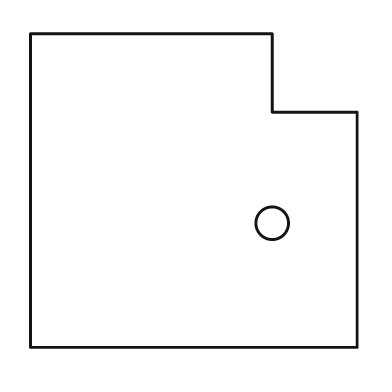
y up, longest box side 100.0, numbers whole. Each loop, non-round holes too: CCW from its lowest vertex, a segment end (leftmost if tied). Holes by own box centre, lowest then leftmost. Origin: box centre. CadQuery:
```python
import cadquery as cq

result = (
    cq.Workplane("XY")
    .moveTo(-50.0, -48.0)
    .lineTo(50.0, -48.0)
    .lineTo(50.0, 24.0)
    .lineTo(24.0, 24.0)
    .lineTo(24.0, 48.0)
    .lineTo(-50.0, 48.0)
    .close()
    .moveTo(24.0, -10.0)
    .circle(5.0)
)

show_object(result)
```